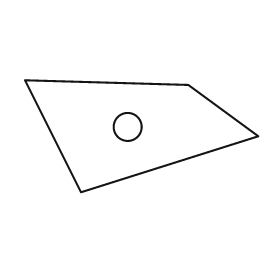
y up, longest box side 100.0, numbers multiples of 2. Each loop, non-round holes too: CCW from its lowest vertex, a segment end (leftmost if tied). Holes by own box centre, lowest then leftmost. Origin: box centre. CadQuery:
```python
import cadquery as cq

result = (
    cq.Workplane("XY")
    .moveTo(-26.0, -24.0)
    .lineTo(50.0, 0.0)
    .lineTo(20.0, 22.0)
    .lineTo(-50.0, 24.0)
    .close()
    .moveTo(-6.0, 4.0)
    .circle(6.0)
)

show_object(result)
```